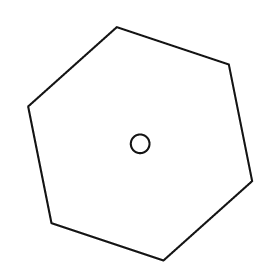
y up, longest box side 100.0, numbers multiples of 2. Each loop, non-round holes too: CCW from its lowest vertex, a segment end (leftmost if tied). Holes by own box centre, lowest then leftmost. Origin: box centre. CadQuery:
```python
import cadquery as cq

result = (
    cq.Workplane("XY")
    .moveTo(10.0, -50.0)
    .lineTo(48.0, -16.0)
    .lineTo(38.0, 34.0)
    .lineTo(-10.0, 50.0)
    .lineTo(-48.0, 16.0)
    .lineTo(-38.0, -34.0)
    .close()
    .moveTo(0.0, 0.0)
    .circle(4.0)
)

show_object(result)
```